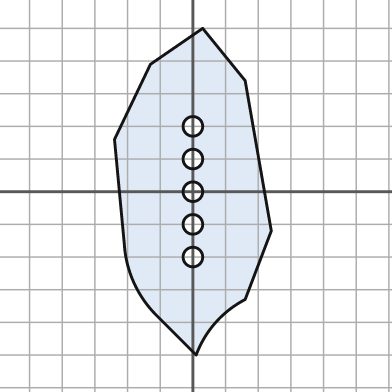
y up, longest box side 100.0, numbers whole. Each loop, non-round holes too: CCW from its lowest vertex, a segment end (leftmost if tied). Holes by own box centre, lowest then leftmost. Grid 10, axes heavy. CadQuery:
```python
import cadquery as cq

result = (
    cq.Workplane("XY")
    .moveTo(1.0, -50.0)
    .threePointArc((7.0, -40.0), (16.0, -33.0))
    .lineTo(24.0, -12.0)
    .lineTo(16.0, 34.0)
    .lineTo(3.0, 50.0)
    .lineTo(-13.0, 39.0)
    .lineTo(-24.0, 16.0)
    .lineTo(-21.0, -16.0)
    .threePointArc((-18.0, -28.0), (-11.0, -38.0))
    .close()
    .moveTo(0.0, -20.0)
    .circle(3.0)
    .moveTo(0.0, -10.0)
    .circle(3.0)
    .moveTo(0.0, 0.0)
    .circle(3.0)
    .moveTo(0.0, 10.0)
    .circle(3.0)
    .moveTo(0.0, 20.0)
    .circle(3.0)
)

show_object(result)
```